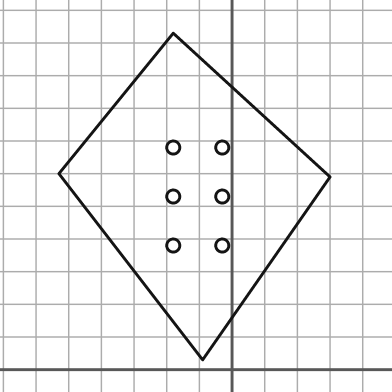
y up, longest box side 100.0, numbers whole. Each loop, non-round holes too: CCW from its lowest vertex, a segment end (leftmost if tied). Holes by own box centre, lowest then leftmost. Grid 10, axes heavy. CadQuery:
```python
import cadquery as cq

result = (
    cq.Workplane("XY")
    .moveTo(-9.0, 3.0)
    .lineTo(30.0, 59.0)
    .lineTo(-18.0, 103.0)
    .lineTo(-53.0, 60.0)
    .close()
    .moveTo(-18.0, 38.0)
    .circle(2.0)
    .moveTo(-3.0, 38.0)
    .circle(2.0)
    .moveTo(-18.0, 53.0)
    .circle(2.0)
    .moveTo(-3.0, 53.0)
    .circle(2.0)
    .moveTo(-18.0, 68.0)
    .circle(2.0)
    .moveTo(-3.0, 68.0)
    .circle(2.0)
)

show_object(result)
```